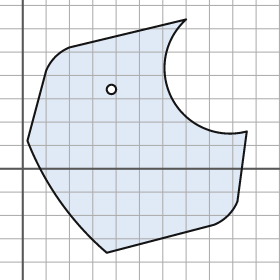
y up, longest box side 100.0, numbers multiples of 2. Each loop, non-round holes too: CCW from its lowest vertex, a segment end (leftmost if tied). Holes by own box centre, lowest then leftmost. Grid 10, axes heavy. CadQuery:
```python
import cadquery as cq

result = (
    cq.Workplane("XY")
    .moveTo(36.0, -36.0)
    .lineTo(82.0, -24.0)
    .threePointArc((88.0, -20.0), (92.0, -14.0))
    .lineTo(96.0, 16.0)
    .threePointArc((64.0, 30.0), (70.0, 64.0))
    .lineTo(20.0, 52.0)
    .threePointArc((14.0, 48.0), (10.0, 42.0))
    .lineTo(2.0, 12.0)
    .threePointArc((16.0, -14.0), (36.0, -36.0))
    .close()
    .moveTo(38.0, 34.0)
    .circle(2.0)
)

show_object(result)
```